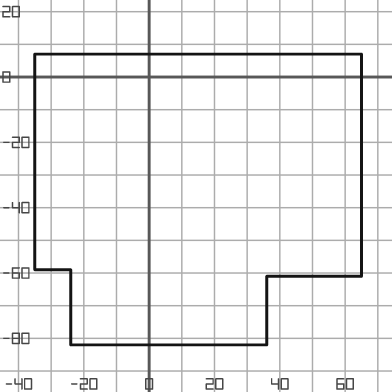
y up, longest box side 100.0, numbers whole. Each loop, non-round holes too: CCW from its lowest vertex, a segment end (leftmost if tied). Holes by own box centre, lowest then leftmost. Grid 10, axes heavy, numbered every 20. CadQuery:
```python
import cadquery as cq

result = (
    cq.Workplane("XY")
    .moveTo(-24.0, -82.0)
    .lineTo(36.0, -82.0)
    .lineTo(36.0, -61.0)
    .lineTo(65.0, -61.0)
    .lineTo(65.0, 7.0)
    .lineTo(-35.0, 7.0)
    .lineTo(-35.0, -59.0)
    .lineTo(-24.0, -59.0)
    .close()
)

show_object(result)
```